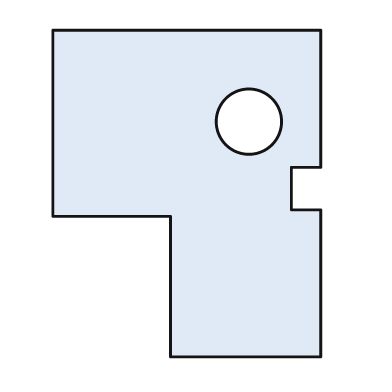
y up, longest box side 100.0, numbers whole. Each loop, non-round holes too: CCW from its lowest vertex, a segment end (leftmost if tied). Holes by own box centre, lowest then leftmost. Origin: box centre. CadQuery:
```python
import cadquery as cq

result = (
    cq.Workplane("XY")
    .moveTo(-5.0, -50.0)
    .lineTo(41.0, -50.0)
    .lineTo(41.0, -5.0)
    .lineTo(32.0, -5.0)
    .lineTo(32.0, 8.0)
    .lineTo(41.0, 8.0)
    .lineTo(41.0, 50.0)
    .lineTo(-41.0, 50.0)
    .lineTo(-41.0, -7.0)
    .lineTo(-5.0, -7.0)
    .close()
    .moveTo(19.0, 22.0)
    .circle(10.0)
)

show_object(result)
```